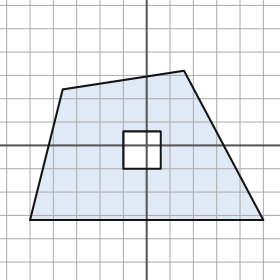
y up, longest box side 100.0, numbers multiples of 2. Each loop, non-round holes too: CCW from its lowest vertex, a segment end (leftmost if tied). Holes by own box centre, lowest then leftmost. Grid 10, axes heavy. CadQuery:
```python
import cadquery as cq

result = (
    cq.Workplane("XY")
    .moveTo(-50.0, -32.0)
    .lineTo(50.0, -32.0)
    .lineTo(16.0, 32.0)
    .lineTo(-36.0, 24.0)
    .close()
    .moveTo(-10.0, -10.0)
    .lineTo(6.0, -10.0)
    .lineTo(6.0, 6.0)
    .lineTo(-10.0, 6.0)
    .close()
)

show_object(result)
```